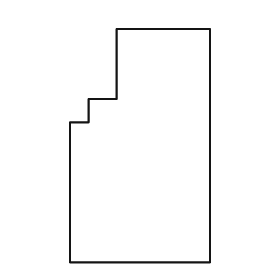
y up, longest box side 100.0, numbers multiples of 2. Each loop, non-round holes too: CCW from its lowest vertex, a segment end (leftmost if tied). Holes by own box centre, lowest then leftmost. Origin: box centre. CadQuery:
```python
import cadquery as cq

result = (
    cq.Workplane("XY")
    .moveTo(-30.0, -50.0)
    .lineTo(30.0, -50.0)
    .lineTo(30.0, 50.0)
    .lineTo(-10.0, 50.0)
    .lineTo(-10.0, 20.0)
    .lineTo(-22.0, 20.0)
    .lineTo(-22.0, 10.0)
    .lineTo(-30.0, 10.0)
    .close()
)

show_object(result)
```